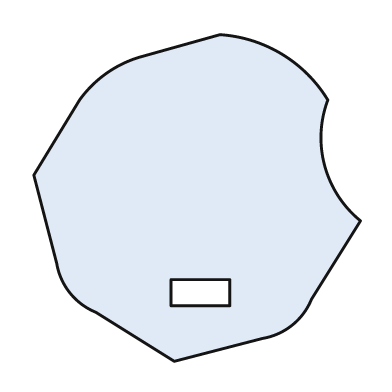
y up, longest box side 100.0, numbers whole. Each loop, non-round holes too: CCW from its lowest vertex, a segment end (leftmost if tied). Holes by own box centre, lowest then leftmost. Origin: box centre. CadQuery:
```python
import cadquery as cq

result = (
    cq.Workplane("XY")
    .moveTo(-7.0, -50.0)
    .lineTo(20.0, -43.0)
    .threePointArc((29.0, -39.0), (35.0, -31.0))
    .lineTo(50.0, -7.0)
    .threePointArc((39.0, 10.0), (40.0, 30.0))
    .threePointArc((26.0, 44.0), (7.0, 50.0))
    .lineTo(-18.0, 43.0)
    .threePointArc((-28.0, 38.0), (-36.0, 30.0))
    .lineTo(-50.0, 7.0)
    .lineTo(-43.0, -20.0)
    .threePointArc((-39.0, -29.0), (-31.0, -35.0))
    .close()
    .moveTo(-8.0, -33.0)
    .lineTo(10.0, -33.0)
    .lineTo(10.0, -25.0)
    .lineTo(-8.0, -25.0)
    .close()
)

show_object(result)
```